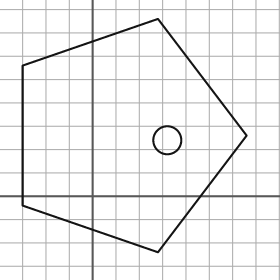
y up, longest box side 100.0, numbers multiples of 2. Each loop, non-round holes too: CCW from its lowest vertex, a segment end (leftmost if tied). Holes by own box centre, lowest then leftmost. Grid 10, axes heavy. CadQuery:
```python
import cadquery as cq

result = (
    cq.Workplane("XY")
    .moveTo(28.0, -24.0)
    .lineTo(66.0, 26.0)
    .lineTo(28.0, 76.0)
    .lineTo(-30.0, 56.0)
    .lineTo(-30.0, -4.0)
    .close()
    .moveTo(32.0, 24.0)
    .circle(6.0)
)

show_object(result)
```